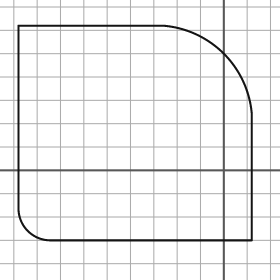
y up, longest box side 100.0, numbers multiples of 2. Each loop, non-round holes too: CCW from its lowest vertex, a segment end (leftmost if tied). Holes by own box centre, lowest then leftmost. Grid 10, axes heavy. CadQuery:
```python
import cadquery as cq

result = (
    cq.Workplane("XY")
    .moveTo(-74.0, -30.0)
    .lineTo(12.0, -30.0)
    .lineTo(12.0, 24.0)
    .threePointArc((0.0, 50.0), (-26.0, 62.0))
    .lineTo(-88.0, 62.0)
    .lineTo(-88.0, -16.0)
    .threePointArc((-84.0, -26.0), (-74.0, -30.0))
    .close()
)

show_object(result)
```